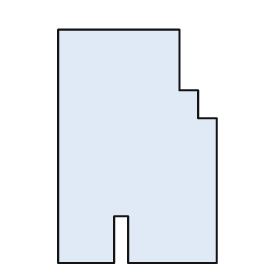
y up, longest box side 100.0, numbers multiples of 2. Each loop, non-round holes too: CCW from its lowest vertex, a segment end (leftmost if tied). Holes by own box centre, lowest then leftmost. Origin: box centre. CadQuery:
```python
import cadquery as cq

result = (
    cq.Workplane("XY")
    .moveTo(-34.0, -50.0)
    .lineTo(-10.0, -50.0)
    .lineTo(-10.0, -30.0)
    .lineTo(-4.0, -30.0)
    .lineTo(-4.0, -50.0)
    .lineTo(34.0, -50.0)
    .lineTo(34.0, 12.0)
    .lineTo(26.0, 12.0)
    .lineTo(26.0, 24.0)
    .lineTo(18.0, 24.0)
    .lineTo(18.0, 50.0)
    .lineTo(-34.0, 50.0)
    .close()
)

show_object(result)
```